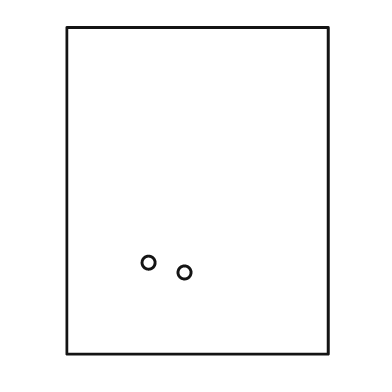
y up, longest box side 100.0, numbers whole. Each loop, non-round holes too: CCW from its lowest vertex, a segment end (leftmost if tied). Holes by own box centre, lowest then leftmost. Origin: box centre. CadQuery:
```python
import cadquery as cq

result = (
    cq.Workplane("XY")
    .moveTo(-40.0, -50.0)
    .lineTo(40.0, -50.0)
    .lineTo(40.0, 50.0)
    .lineTo(-40.0, 50.0)
    .close()
    .moveTo(-4.0, -25.0)
    .circle(2.0)
    .moveTo(-15.0, -22.0)
    .circle(2.0)
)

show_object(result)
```